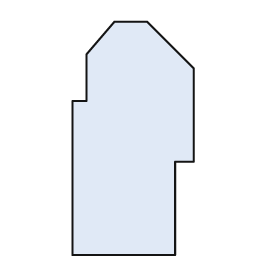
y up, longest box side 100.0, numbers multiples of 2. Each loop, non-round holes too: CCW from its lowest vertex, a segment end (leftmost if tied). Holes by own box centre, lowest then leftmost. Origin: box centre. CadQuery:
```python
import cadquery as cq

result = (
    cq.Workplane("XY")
    .moveTo(-26.0, -50.0)
    .lineTo(18.0, -50.0)
    .lineTo(18.0, -10.0)
    .lineTo(26.0, -10.0)
    .lineTo(26.0, 30.0)
    .lineTo(6.0, 50.0)
    .lineTo(-8.0, 50.0)
    .lineTo(-20.0, 36.0)
    .lineTo(-20.0, 16.0)
    .lineTo(-26.0, 16.0)
    .close()
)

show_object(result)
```